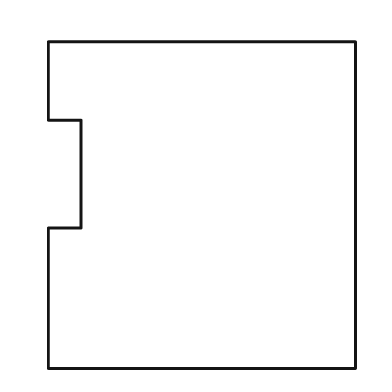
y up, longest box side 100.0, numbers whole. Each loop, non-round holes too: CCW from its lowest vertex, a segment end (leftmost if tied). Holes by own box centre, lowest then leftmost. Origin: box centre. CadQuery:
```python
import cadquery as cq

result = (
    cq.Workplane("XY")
    .moveTo(-47.0, -50.0)
    .lineTo(47.0, -50.0)
    .lineTo(47.0, 50.0)
    .lineTo(-47.0, 50.0)
    .lineTo(-47.0, 26.0)
    .lineTo(-37.0, 26.0)
    .lineTo(-37.0, -7.0)
    .lineTo(-47.0, -7.0)
    .close()
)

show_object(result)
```